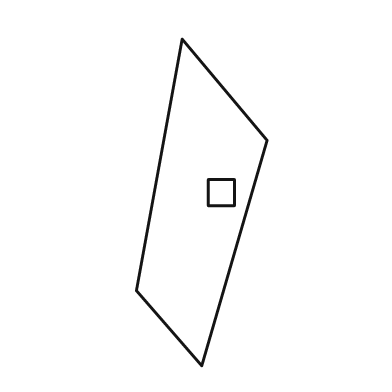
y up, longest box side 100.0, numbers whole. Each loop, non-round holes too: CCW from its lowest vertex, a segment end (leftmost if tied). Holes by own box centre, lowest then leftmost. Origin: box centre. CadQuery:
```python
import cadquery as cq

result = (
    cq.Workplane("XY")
    .moveTo(0.0, -50.0)
    .lineTo(20.0, 19.0)
    .lineTo(-6.0, 50.0)
    .lineTo(-20.0, -27.0)
    .close()
    .moveTo(2.0, -1.0)
    .lineTo(10.0, -1.0)
    .lineTo(10.0, 7.0)
    .lineTo(2.0, 7.0)
    .close()
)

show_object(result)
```